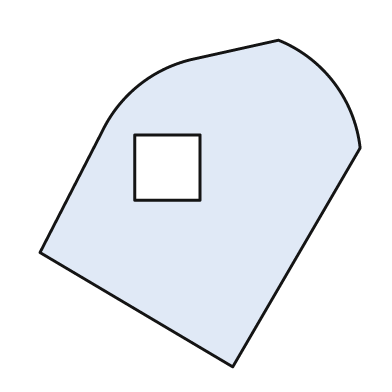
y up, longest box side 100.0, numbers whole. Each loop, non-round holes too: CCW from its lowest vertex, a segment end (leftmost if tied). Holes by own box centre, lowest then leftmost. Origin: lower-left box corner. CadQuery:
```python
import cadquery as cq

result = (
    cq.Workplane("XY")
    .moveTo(59.0, 0.0)
    .lineTo(98.0, 67.0)
    .threePointArc((90.0, 87.0), (73.0, 100.0))
    .lineTo(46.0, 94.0)
    .threePointArc((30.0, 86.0), (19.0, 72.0))
    .lineTo(0.0, 35.0)
    .close()
    .moveTo(29.0, 51.0)
    .lineTo(49.0, 51.0)
    .lineTo(49.0, 71.0)
    .lineTo(29.0, 71.0)
    .close()
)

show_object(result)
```